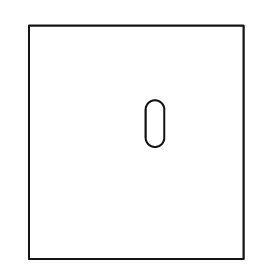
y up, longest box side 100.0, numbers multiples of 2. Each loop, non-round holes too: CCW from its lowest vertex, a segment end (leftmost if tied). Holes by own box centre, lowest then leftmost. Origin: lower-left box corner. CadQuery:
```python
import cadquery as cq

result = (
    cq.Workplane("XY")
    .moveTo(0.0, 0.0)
    .lineTo(92.0, 0.0)
    .lineTo(92.0, 100.0)
    .lineTo(0.0, 100.0)
    .close()
    .moveTo(50.0, 52.0)
    .threePointArc((54.0, 48.0), (58.0, 52.0))
    .lineTo(58.0, 64.0)
    .threePointArc((54.0, 68.0), (50.0, 64.0))
    .close()
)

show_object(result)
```